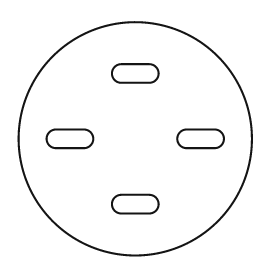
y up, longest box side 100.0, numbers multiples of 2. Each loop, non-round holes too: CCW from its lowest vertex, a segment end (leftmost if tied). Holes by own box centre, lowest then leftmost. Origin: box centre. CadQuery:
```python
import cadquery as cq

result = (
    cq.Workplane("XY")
    .moveTo(0.0, 0.0)
    .circle(50.0)
    .moveTo(-6.0, -32.0)
    .lineTo(6.0, -32.0)
    .threePointArc((10.0, -28.0), (6.0, -24.0))
    .lineTo(-6.0, -24.0)
    .threePointArc((-10.0, -28.0), (-6.0, -32.0))
    .close()
    .moveTo(-34.0, -4.0)
    .lineTo(-22.0, -4.0)
    .threePointArc((-18.0, 0.0), (-22.0, 4.0))
    .lineTo(-34.0, 4.0)
    .threePointArc((-38.0, 0.0), (-34.0, -4.0))
    .close()
    .moveTo(22.0, -4.0)
    .lineTo(34.0, -4.0)
    .threePointArc((38.0, 0.0), (34.0, 4.0))
    .lineTo(22.0, 4.0)
    .threePointArc((18.0, 0.0), (22.0, -4.0))
    .close()
    .moveTo(-6.0, 24.0)
    .lineTo(6.0, 24.0)
    .threePointArc((10.0, 28.0), (6.0, 32.0))
    .lineTo(-6.0, 32.0)
    .threePointArc((-10.0, 28.0), (-6.0, 24.0))
    .close()
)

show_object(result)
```